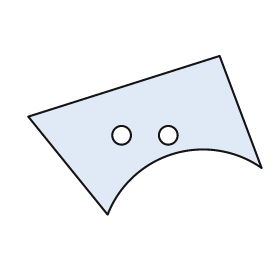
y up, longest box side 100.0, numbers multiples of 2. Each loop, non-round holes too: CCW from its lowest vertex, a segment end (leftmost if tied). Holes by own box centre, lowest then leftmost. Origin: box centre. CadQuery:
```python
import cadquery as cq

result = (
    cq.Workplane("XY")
    .moveTo(-16.0, -34.0)
    .threePointArc((12.0, -8.0), (50.0, -14.0))
    .lineTo(32.0, 34.0)
    .lineTo(-50.0, 8.0)
    .close()
    .moveTo(-10.0, 0.0)
    .circle(4.0)
    .moveTo(10.0, 0.0)
    .circle(4.0)
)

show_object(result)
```